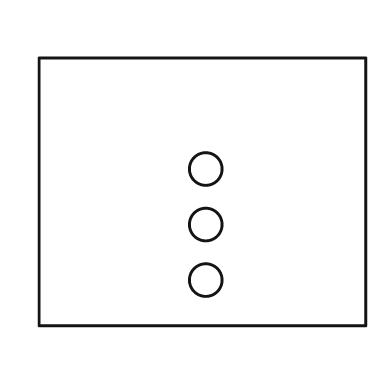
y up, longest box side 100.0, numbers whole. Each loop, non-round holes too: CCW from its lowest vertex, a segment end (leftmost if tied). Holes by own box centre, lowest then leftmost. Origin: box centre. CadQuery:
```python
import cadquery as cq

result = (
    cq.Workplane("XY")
    .moveTo(-50.0, -41.0)
    .lineTo(50.0, -41.0)
    .lineTo(50.0, 41.0)
    .lineTo(-50.0, 41.0)
    .close()
    .moveTo(1.0, -27.0)
    .circle(5.0)
    .moveTo(1.0, -10.0)
    .circle(5.0)
    .moveTo(1.0, 7.0)
    .circle(5.0)
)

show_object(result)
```